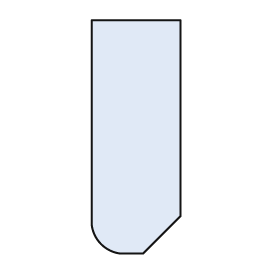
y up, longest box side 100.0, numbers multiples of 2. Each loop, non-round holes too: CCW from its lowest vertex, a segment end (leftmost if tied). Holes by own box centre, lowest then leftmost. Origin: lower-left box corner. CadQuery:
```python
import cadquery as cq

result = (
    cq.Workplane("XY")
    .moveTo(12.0, 0.0)
    .lineTo(22.0, 0.0)
    .lineTo(38.0, 16.0)
    .lineTo(38.0, 100.0)
    .lineTo(0.0, 100.0)
    .lineTo(0.0, 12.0)
    .threePointArc((4.0, 4.0), (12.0, 0.0))
    .close()
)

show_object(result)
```